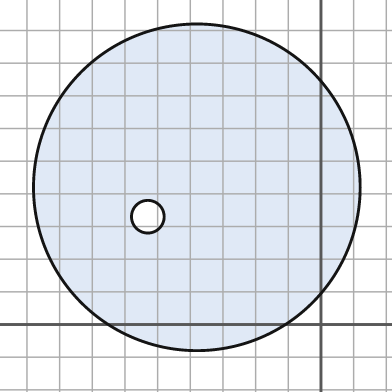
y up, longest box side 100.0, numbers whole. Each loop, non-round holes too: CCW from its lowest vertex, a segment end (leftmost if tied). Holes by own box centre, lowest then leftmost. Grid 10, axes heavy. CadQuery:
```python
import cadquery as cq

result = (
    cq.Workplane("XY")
    .moveTo(-38.0, 42.0)
    .circle(50.0)
    .moveTo(-53.0, 33.0)
    .circle(5.0)
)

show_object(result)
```